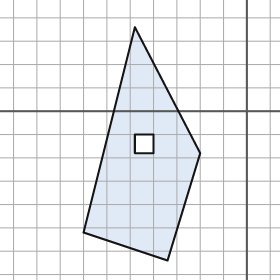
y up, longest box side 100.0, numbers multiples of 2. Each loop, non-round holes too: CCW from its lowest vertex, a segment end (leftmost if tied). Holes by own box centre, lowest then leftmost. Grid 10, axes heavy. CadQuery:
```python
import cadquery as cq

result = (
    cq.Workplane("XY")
    .moveTo(-34.0, -64.0)
    .lineTo(-20.0, -18.0)
    .lineTo(-48.0, 36.0)
    .lineTo(-70.0, -52.0)
    .close()
    .moveTo(-48.0, -18.0)
    .lineTo(-40.0, -18.0)
    .lineTo(-40.0, -10.0)
    .lineTo(-48.0, -10.0)
    .close()
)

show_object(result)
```